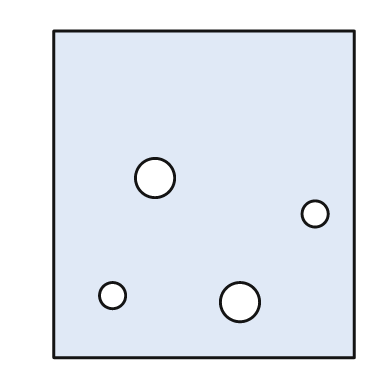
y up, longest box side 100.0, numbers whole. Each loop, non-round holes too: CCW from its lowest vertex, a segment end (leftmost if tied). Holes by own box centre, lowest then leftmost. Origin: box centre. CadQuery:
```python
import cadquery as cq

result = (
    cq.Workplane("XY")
    .moveTo(-46.0, -50.0)
    .lineTo(46.0, -50.0)
    .lineTo(46.0, 50.0)
    .lineTo(-46.0, 50.0)
    .close()
    .moveTo(11.0, -33.0)
    .circle(6.0)
    .moveTo(-28.0, -31.0)
    .circle(4.0)
    .moveTo(34.0, -6.0)
    .circle(4.0)
    .moveTo(-15.0, 5.0)
    .circle(6.0)
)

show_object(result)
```